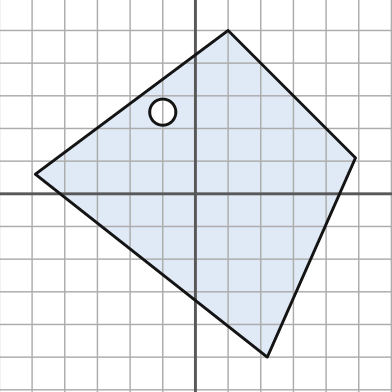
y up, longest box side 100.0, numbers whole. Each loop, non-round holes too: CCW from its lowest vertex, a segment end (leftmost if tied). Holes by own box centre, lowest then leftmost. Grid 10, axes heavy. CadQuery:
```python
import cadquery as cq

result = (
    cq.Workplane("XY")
    .moveTo(22.0, -50.0)
    .lineTo(49.0, 11.0)
    .lineTo(10.0, 50.0)
    .lineTo(-49.0, 6.0)
    .close()
    .moveTo(-10.0, 25.0)
    .circle(4.0)
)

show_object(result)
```